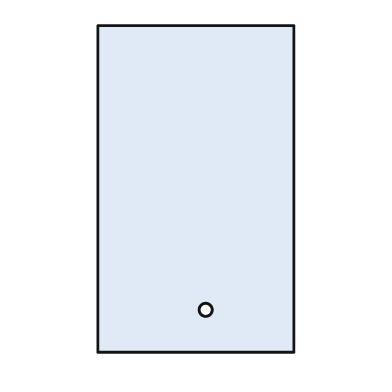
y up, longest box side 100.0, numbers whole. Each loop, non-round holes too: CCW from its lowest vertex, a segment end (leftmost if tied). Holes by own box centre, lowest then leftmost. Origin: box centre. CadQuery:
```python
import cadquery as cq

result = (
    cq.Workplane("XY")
    .moveTo(-30.0, -50.0)
    .lineTo(30.0, -50.0)
    .lineTo(30.0, 50.0)
    .lineTo(-30.0, 50.0)
    .close()
    .moveTo(3.0, -37.0)
    .circle(2.0)
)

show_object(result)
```